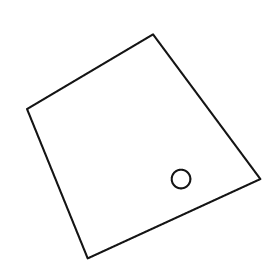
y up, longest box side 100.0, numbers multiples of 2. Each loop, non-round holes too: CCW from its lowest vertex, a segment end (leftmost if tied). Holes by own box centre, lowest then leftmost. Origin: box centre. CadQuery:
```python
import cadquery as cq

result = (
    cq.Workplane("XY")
    .moveTo(-24.0, -48.0)
    .lineTo(50.0, -14.0)
    .lineTo(4.0, 48.0)
    .lineTo(-50.0, 16.0)
    .close()
    .moveTo(16.0, -14.0)
    .circle(4.0)
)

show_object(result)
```